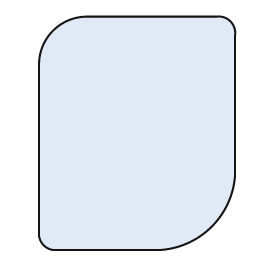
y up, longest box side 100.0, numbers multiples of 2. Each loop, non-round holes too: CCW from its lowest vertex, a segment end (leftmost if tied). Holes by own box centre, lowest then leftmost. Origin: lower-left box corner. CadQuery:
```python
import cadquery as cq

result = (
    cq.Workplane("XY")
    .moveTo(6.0, 0.0)
    .lineTo(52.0, 0.0)
    .threePointArc((74.0, 10.0), (84.0, 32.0))
    .lineTo(84.0, 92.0)
    .threePointArc((82.0, 98.0), (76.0, 100.0))
    .lineTo(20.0, 100.0)
    .threePointArc((6.0, 94.0), (0.0, 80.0))
    .lineTo(0.0, 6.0)
    .threePointArc((2.0, 2.0), (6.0, 0.0))
    .close()
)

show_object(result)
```